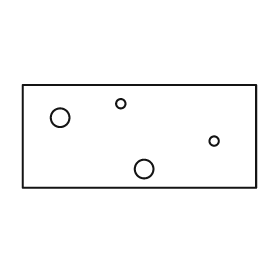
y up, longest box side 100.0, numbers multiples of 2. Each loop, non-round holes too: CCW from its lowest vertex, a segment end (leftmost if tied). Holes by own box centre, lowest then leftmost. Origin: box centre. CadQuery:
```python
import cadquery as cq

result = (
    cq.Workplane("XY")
    .moveTo(-50.0, -22.0)
    .lineTo(50.0, -22.0)
    .lineTo(50.0, 22.0)
    .lineTo(-50.0, 22.0)
    .close()
    .moveTo(2.0, -14.0)
    .circle(4.0)
    .moveTo(32.0, -2.0)
    .circle(2.0)
    .moveTo(-34.0, 8.0)
    .circle(4.0)
    .moveTo(-8.0, 14.0)
    .circle(2.0)
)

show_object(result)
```